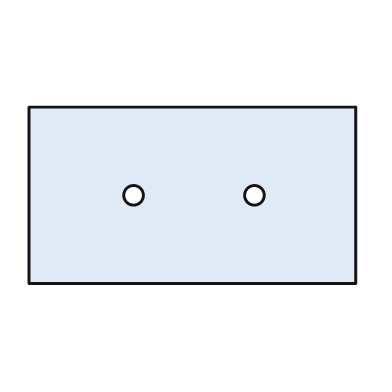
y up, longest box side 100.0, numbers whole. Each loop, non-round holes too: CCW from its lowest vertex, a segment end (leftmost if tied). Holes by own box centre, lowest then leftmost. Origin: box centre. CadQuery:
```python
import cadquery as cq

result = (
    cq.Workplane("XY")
    .moveTo(-50.0, -27.0)
    .lineTo(50.0, -27.0)
    .lineTo(50.0, 27.0)
    .lineTo(-50.0, 27.0)
    .close()
    .moveTo(-18.0, 0.0)
    .circle(3.0)
    .moveTo(19.0, 0.0)
    .circle(3.0)
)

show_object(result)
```